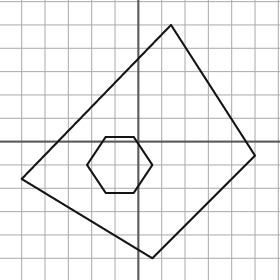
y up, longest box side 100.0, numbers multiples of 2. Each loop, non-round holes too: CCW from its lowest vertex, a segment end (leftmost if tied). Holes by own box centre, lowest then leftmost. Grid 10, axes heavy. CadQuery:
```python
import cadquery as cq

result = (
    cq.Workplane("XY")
    .moveTo(6.0, -50.0)
    .lineTo(50.0, -6.0)
    .lineTo(14.0, 50.0)
    .lineTo(-50.0, -16.0)
    .close()
    .moveTo(-14.0, -22.0)
    .lineTo(-2.0, -22.0)
    .lineTo(6.0, -10.0)
    .lineTo(-2.0, 2.0)
    .lineTo(-14.0, 2.0)
    .lineTo(-22.0, -10.0)
    .close()
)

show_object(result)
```